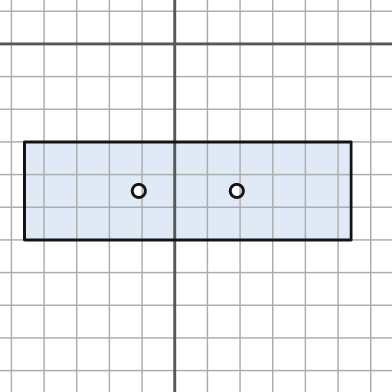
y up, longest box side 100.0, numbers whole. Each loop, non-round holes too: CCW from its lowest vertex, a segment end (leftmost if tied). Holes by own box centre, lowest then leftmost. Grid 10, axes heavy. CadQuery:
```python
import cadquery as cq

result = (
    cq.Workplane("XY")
    .moveTo(-46.0, -60.0)
    .lineTo(54.0, -60.0)
    .lineTo(54.0, -30.0)
    .lineTo(-46.0, -30.0)
    .close()
    .moveTo(-11.0, -45.0)
    .circle(2.0)
    .moveTo(19.0, -45.0)
    .circle(2.0)
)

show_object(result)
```